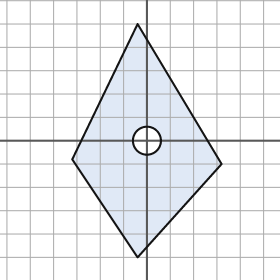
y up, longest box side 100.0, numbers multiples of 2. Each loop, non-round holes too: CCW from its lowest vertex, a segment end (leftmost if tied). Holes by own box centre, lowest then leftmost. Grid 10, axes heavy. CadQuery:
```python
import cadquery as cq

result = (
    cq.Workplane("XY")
    .moveTo(-4.0, -50.0)
    .lineTo(32.0, -10.0)
    .lineTo(-4.0, 50.0)
    .lineTo(-32.0, -8.0)
    .close()
    .moveTo(0.0, 0.0)
    .circle(6.0)
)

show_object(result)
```